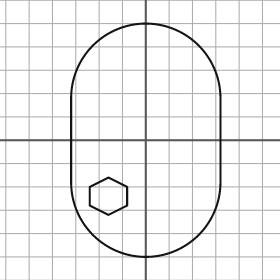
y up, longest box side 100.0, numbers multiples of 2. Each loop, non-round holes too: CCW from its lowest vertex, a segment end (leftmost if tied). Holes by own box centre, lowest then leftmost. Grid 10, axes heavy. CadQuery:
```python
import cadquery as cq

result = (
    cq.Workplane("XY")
    .moveTo(-32.0, -18.0)
    .threePointArc((0.0, -50.0), (32.0, -18.0))
    .lineTo(32.0, 18.0)
    .threePointArc((0.0, 50.0), (-32.0, 18.0))
    .close()
    .moveTo(-16.0, -32.0)
    .lineTo(-8.0, -28.0)
    .lineTo(-8.0, -20.0)
    .lineTo(-16.0, -16.0)
    .lineTo(-24.0, -20.0)
    .lineTo(-24.0, -28.0)
    .close()
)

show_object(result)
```